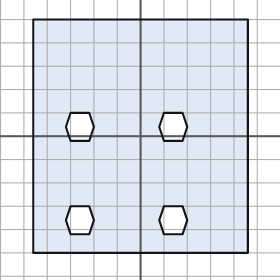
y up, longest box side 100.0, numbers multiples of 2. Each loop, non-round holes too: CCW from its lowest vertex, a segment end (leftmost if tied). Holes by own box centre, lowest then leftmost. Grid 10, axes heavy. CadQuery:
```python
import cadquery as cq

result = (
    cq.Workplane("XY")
    .moveTo(-46.0, -50.0)
    .lineTo(46.0, -50.0)
    .lineTo(46.0, 50.0)
    .lineTo(-46.0, 50.0)
    .close()
    .moveTo(-30.0, -42.0)
    .lineTo(-22.0, -42.0)
    .lineTo(-20.0, -36.0)
    .lineTo(-22.0, -30.0)
    .lineTo(-30.0, -30.0)
    .lineTo(-32.0, -36.0)
    .close()
    .moveTo(10.0, -42.0)
    .lineTo(18.0, -42.0)
    .lineTo(20.0, -36.0)
    .lineTo(18.0, -30.0)
    .lineTo(10.0, -30.0)
    .lineTo(8.0, -36.0)
    .close()
    .moveTo(-30.0, -2.0)
    .lineTo(-22.0, -2.0)
    .lineTo(-20.0, 4.0)
    .lineTo(-22.0, 10.0)
    .lineTo(-30.0, 10.0)
    .lineTo(-32.0, 4.0)
    .close()
    .moveTo(10.0, -2.0)
    .lineTo(18.0, -2.0)
    .lineTo(20.0, 4.0)
    .lineTo(18.0, 10.0)
    .lineTo(10.0, 10.0)
    .lineTo(8.0, 4.0)
    .close()
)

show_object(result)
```